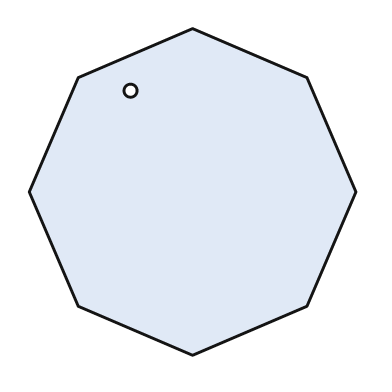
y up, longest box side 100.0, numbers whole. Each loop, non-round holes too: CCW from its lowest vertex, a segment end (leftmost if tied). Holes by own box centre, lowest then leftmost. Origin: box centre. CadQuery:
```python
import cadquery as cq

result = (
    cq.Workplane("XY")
    .moveTo(0.0, -50.0)
    .lineTo(35.0, -35.0)
    .lineTo(50.0, 0.0)
    .lineTo(35.0, 35.0)
    .lineTo(0.0, 50.0)
    .lineTo(-35.0, 35.0)
    .lineTo(-50.0, 0.0)
    .lineTo(-35.0, -35.0)
    .close()
    .moveTo(-19.0, 31.0)
    .circle(2.0)
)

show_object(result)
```